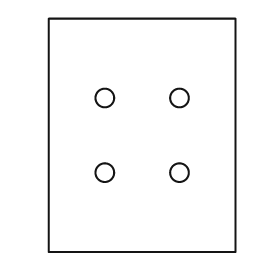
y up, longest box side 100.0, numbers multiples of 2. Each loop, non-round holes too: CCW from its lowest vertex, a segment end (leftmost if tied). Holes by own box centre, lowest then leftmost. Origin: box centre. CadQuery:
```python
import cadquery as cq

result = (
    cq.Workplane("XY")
    .moveTo(-40.0, -50.0)
    .lineTo(40.0, -50.0)
    .lineTo(40.0, 50.0)
    .lineTo(-40.0, 50.0)
    .close()
    .moveTo(-16.0, -16.0)
    .circle(4.0)
    .moveTo(16.0, -16.0)
    .circle(4.0)
    .moveTo(-16.0, 16.0)
    .circle(4.0)
    .moveTo(16.0, 16.0)
    .circle(4.0)
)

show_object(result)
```